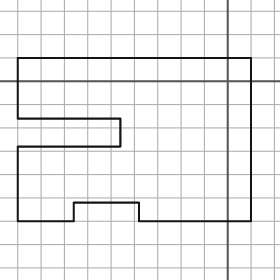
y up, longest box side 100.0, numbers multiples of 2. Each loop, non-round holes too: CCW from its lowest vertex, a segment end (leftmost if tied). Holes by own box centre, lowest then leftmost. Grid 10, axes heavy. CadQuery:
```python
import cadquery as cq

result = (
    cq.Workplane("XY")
    .moveTo(-90.0, -60.0)
    .lineTo(-66.0, -60.0)
    .lineTo(-66.0, -52.0)
    .lineTo(-38.0, -52.0)
    .lineTo(-38.0, -60.0)
    .lineTo(10.0, -60.0)
    .lineTo(10.0, 10.0)
    .lineTo(-90.0, 10.0)
    .lineTo(-90.0, -16.0)
    .lineTo(-46.0, -16.0)
    .lineTo(-46.0, -28.0)
    .lineTo(-90.0, -28.0)
    .close()
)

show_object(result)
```